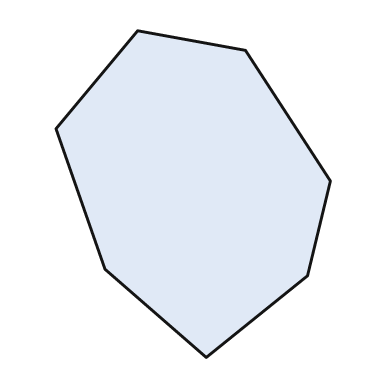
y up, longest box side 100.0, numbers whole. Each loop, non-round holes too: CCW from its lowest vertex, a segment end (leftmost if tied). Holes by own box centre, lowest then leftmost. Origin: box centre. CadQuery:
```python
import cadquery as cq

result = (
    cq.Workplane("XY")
    .moveTo(4.0, -50.0)
    .lineTo(35.0, -25.0)
    .lineTo(42.0, 4.0)
    .lineTo(16.0, 44.0)
    .lineTo(-17.0, 50.0)
    .lineTo(-42.0, 20.0)
    .lineTo(-27.0, -23.0)
    .close()
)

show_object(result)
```